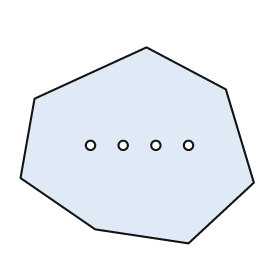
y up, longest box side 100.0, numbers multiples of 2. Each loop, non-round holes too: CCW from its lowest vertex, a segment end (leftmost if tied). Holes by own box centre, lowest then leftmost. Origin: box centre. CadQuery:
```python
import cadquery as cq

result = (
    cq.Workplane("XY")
    .moveTo(22.0, -42.0)
    .lineTo(50.0, -16.0)
    .lineTo(38.0, 24.0)
    .lineTo(4.0, 42.0)
    .lineTo(-44.0, 20.0)
    .lineTo(-50.0, -14.0)
    .lineTo(-18.0, -36.0)
    .close()
    .moveTo(-20.0, 0.0)
    .circle(2.0)
    .moveTo(-6.0, 0.0)
    .circle(2.0)
    .moveTo(8.0, 0.0)
    .circle(2.0)
    .moveTo(22.0, 0.0)
    .circle(2.0)
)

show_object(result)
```